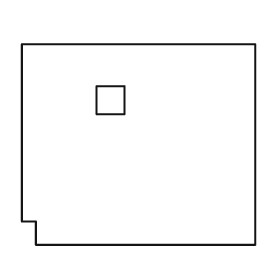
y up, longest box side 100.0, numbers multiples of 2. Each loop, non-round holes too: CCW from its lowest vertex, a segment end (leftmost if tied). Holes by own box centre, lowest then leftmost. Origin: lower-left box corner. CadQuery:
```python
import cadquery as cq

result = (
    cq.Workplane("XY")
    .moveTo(6.0, 0.0)
    .lineTo(100.0, 0.0)
    .lineTo(100.0, 86.0)
    .lineTo(0.0, 86.0)
    .lineTo(0.0, 10.0)
    .lineTo(6.0, 10.0)
    .close()
    .moveTo(32.0, 56.0)
    .lineTo(44.0, 56.0)
    .lineTo(44.0, 68.0)
    .lineTo(32.0, 68.0)
    .close()
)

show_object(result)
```